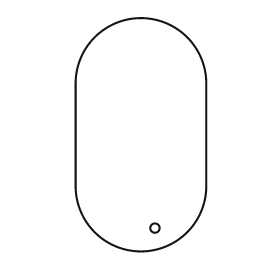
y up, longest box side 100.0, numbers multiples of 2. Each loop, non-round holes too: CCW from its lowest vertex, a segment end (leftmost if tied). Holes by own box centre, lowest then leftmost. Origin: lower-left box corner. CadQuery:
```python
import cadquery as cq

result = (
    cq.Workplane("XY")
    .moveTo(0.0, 28.0)
    .threePointArc((28.0, 0.0), (56.0, 28.0))
    .lineTo(56.0, 72.0)
    .threePointArc((28.0, 100.0), (0.0, 72.0))
    .close()
    .moveTo(34.0, 10.0)
    .circle(2.0)
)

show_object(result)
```